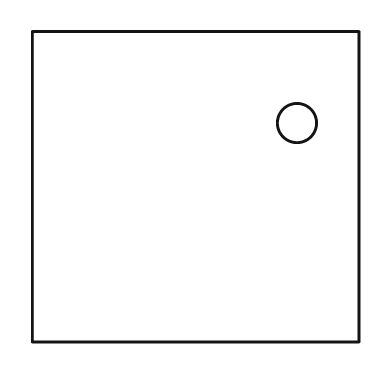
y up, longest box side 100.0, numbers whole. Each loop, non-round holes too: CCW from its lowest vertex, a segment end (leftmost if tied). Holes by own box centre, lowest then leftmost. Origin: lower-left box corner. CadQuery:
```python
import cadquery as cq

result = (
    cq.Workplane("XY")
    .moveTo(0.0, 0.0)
    .lineTo(100.0, 0.0)
    .lineTo(100.0, 95.0)
    .lineTo(0.0, 95.0)
    .close()
    .moveTo(81.0, 67.0)
    .circle(6.0)
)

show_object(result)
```